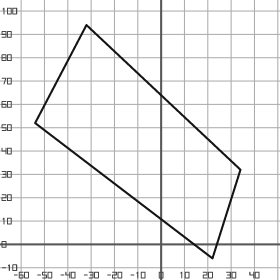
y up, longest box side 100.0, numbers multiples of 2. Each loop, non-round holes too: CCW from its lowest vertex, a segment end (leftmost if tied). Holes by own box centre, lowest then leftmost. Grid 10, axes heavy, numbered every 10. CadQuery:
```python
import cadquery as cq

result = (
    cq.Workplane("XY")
    .moveTo(22.0, -6.0)
    .lineTo(34.0, 32.0)
    .lineTo(-32.0, 94.0)
    .lineTo(-54.0, 52.0)
    .close()
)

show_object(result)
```